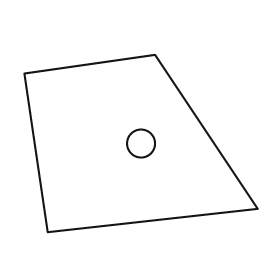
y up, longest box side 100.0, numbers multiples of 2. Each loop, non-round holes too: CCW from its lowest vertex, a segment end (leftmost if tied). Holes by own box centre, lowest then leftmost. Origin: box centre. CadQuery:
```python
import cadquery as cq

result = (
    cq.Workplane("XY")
    .moveTo(-40.0, -38.0)
    .lineTo(50.0, -28.0)
    .lineTo(6.0, 38.0)
    .lineTo(-50.0, 30.0)
    .close()
    .moveTo(0.0, 0.0)
    .circle(6.0)
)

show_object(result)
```